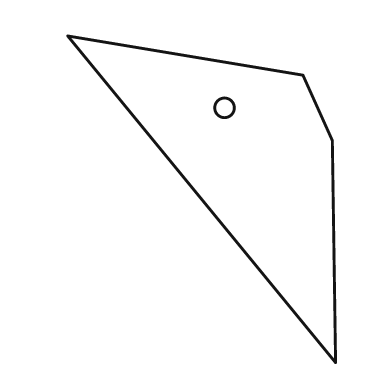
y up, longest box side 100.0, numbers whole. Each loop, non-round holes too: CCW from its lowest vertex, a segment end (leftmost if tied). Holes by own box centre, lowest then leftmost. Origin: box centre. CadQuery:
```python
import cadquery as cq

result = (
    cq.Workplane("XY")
    .moveTo(41.0, -50.0)
    .lineTo(40.0, 18.0)
    .lineTo(31.0, 38.0)
    .lineTo(-41.0, 50.0)
    .close()
    .moveTo(7.0, 28.0)
    .circle(3.0)
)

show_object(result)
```